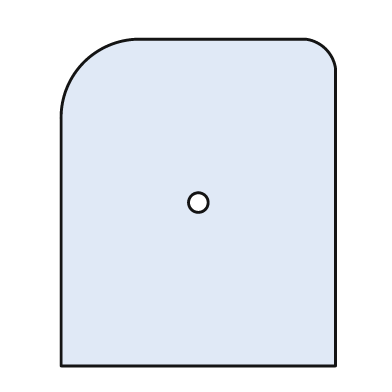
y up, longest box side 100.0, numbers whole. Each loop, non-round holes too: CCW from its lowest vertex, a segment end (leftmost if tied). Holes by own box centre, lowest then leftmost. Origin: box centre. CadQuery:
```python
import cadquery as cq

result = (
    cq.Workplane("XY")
    .moveTo(-42.0, -50.0)
    .lineTo(42.0, -50.0)
    .lineTo(42.0, 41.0)
    .threePointArc((39.0, 47.0), (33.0, 50.0))
    .lineTo(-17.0, 50.0)
    .threePointArc((-35.0, 43.0), (-42.0, 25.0))
    .close()
    .moveTo(0.0, 0.0)
    .circle(3.0)
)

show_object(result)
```